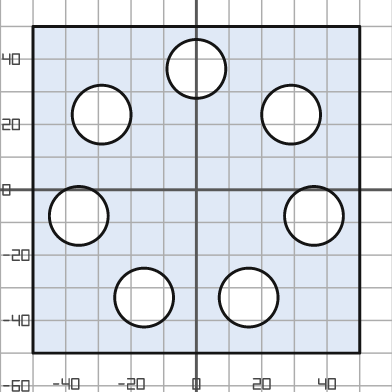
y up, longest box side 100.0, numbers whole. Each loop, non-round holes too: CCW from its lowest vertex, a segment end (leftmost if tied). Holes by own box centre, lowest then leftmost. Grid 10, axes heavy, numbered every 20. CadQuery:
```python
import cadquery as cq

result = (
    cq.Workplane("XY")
    .moveTo(-50.0, -50.0)
    .lineTo(50.0, -50.0)
    .lineTo(50.0, 50.0)
    .lineTo(-50.0, 50.0)
    .close()
    .moveTo(-16.0, -33.0)
    .circle(9.0)
    .moveTo(16.0, -33.0)
    .circle(9.0)
    .moveTo(-36.0, -8.0)
    .circle(9.0)
    .moveTo(36.0, -8.0)
    .circle(9.0)
    .moveTo(-29.0, 23.0)
    .circle(9.0)
    .moveTo(29.0, 23.0)
    .circle(9.0)
    .moveTo(0.0, 37.0)
    .circle(9.0)
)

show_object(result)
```